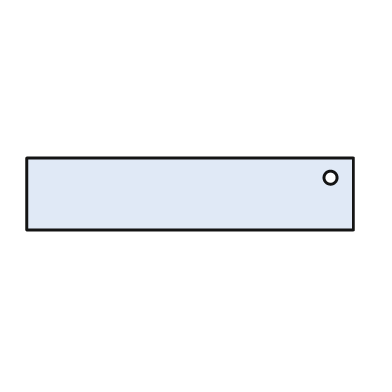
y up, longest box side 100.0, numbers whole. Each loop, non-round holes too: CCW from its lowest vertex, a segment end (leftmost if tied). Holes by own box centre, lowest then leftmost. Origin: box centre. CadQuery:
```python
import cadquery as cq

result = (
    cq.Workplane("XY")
    .moveTo(-50.0, -11.0)
    .lineTo(50.0, -11.0)
    .lineTo(50.0, 11.0)
    .lineTo(-50.0, 11.0)
    .close()
    .moveTo(43.0, 5.0)
    .circle(2.0)
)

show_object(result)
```